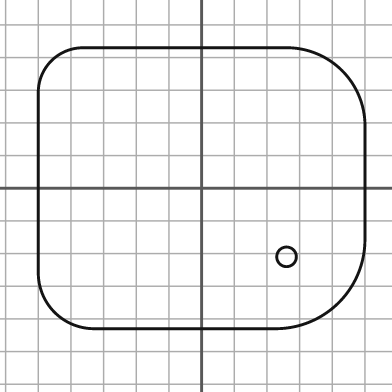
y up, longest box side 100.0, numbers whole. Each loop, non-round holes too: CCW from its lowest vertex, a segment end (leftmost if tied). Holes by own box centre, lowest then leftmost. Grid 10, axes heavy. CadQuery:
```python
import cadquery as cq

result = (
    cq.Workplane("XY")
    .moveTo(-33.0, -43.0)
    .lineTo(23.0, -43.0)
    .threePointArc((42.0, -35.0), (50.0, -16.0))
    .lineTo(50.0, 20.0)
    .threePointArc((43.0, 36.0), (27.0, 43.0))
    .lineTo(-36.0, 43.0)
    .threePointArc((-46.0, 39.0), (-50.0, 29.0))
    .lineTo(-50.0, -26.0)
    .threePointArc((-45.0, -38.0), (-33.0, -43.0))
    .close()
    .moveTo(26.0, -21.0)
    .circle(3.0)
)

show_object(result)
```